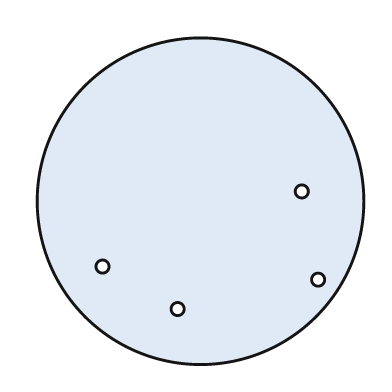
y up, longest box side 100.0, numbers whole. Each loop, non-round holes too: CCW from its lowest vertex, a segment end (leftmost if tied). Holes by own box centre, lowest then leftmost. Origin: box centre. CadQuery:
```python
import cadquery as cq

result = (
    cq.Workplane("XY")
    .moveTo(0.0, 0.0)
    .circle(50.0)
    .moveTo(-7.0, -33.0)
    .circle(2.0)
    .moveTo(36.0, -24.0)
    .circle(2.0)
    .moveTo(-30.0, -20.0)
    .circle(2.0)
    .moveTo(31.0, 3.0)
    .circle(2.0)
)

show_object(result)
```